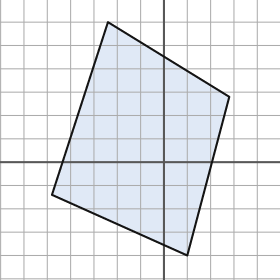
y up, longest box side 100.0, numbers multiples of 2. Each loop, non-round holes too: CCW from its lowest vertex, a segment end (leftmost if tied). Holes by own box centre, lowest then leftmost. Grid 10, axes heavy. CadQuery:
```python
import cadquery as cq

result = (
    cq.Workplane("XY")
    .moveTo(10.0, -40.0)
    .lineTo(28.0, 28.0)
    .lineTo(-24.0, 60.0)
    .lineTo(-48.0, -14.0)
    .close()
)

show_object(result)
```